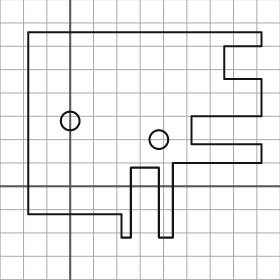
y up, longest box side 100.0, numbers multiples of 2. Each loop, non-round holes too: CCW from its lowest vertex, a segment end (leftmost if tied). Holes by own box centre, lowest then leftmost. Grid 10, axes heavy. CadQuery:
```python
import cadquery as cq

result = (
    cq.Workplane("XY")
    .moveTo(22.0, -22.0)
    .lineTo(26.0, -22.0)
    .lineTo(26.0, 8.0)
    .lineTo(38.0, 8.0)
    .lineTo(38.0, -22.0)
    .lineTo(44.0, -22.0)
    .lineTo(44.0, 10.0)
    .lineTo(82.0, 10.0)
    .lineTo(82.0, 18.0)
    .lineTo(52.0, 18.0)
    .lineTo(52.0, 30.0)
    .lineTo(82.0, 30.0)
    .lineTo(82.0, 46.0)
    .lineTo(66.0, 46.0)
    .lineTo(66.0, 60.0)
    .lineTo(82.0, 60.0)
    .lineTo(82.0, 66.0)
    .lineTo(-18.0, 66.0)
    .lineTo(-18.0, -12.0)
    .lineTo(22.0, -12.0)
    .close()
    .moveTo(38.0, 20.0)
    .circle(4.0)
    .moveTo(0.0, 28.0)
    .circle(4.0)
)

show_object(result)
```